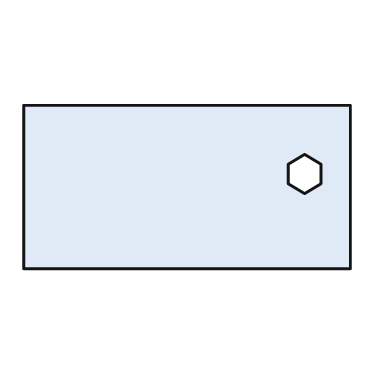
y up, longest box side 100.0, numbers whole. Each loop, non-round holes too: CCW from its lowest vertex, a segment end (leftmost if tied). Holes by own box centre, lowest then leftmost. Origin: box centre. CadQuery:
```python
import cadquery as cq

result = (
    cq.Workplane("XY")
    .moveTo(-50.0, -25.0)
    .lineTo(50.0, -25.0)
    .lineTo(50.0, 25.0)
    .lineTo(-50.0, 25.0)
    .close()
    .moveTo(36.0, -2.0)
    .lineTo(41.0, 1.0)
    .lineTo(41.0, 7.0)
    .lineTo(36.0, 10.0)
    .lineTo(31.0, 7.0)
    .lineTo(31.0, 1.0)
    .close()
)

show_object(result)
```